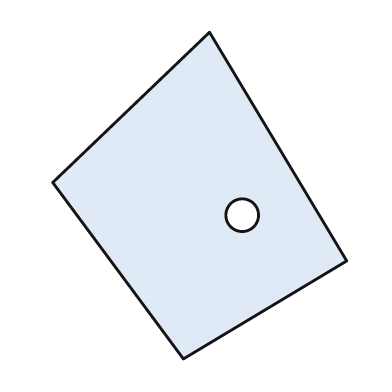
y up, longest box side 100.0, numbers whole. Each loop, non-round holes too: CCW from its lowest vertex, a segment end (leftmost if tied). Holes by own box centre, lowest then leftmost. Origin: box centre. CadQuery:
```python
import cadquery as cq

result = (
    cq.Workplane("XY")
    .moveTo(-5.0, -50.0)
    .lineTo(45.0, -20.0)
    .lineTo(3.0, 50.0)
    .lineTo(-45.0, 4.0)
    .close()
    .moveTo(13.0, -6.0)
    .circle(5.0)
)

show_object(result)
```